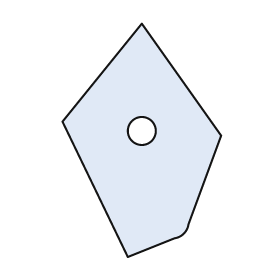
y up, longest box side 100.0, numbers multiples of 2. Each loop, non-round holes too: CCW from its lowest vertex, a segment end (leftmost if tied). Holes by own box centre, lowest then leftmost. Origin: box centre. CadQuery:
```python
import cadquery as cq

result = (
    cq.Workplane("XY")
    .moveTo(-6.0, -50.0)
    .lineTo(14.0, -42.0)
    .threePointArc((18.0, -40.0), (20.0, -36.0))
    .lineTo(34.0, 2.0)
    .lineTo(0.0, 50.0)
    .lineTo(-34.0, 8.0)
    .close()
    .moveTo(0.0, 4.0)
    .circle(6.0)
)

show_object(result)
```